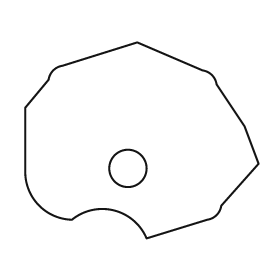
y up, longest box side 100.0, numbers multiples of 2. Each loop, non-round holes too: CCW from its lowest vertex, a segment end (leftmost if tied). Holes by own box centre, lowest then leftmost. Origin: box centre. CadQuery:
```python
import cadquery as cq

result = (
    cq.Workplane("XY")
    .moveTo(2.0, -42.0)
    .lineTo(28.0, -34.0)
    .threePointArc((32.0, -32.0), (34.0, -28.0))
    .lineTo(50.0, -10.0)
    .lineTo(44.0, 6.0)
    .lineTo(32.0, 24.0)
    .threePointArc((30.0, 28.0), (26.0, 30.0))
    .lineTo(-2.0, 42.0)
    .lineTo(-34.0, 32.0)
    .threePointArc((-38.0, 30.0), (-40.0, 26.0))
    .lineTo(-50.0, 14.0)
    .lineTo(-50.0, -14.0)
    .threePointArc((-44.0, -28.0), (-30.0, -34.0))
    .threePointArc((-12.0, -30.0), (2.0, -42.0))
    .close()
    .moveTo(-6.0, -12.0)
    .circle(8.0)
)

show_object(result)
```